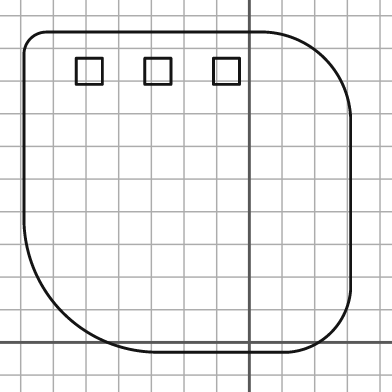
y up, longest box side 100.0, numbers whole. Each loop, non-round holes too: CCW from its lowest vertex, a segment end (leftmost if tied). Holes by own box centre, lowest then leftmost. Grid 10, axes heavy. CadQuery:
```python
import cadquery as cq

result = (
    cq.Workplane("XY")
    .moveTo(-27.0, -3.0)
    .lineTo(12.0, -3.0)
    .threePointArc((25.0, 3.0), (31.0, 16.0))
    .lineTo(31.0, 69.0)
    .threePointArc((23.0, 87.0), (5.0, 95.0))
    .lineTo(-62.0, 95.0)
    .threePointArc((-67.0, 93.0), (-69.0, 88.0))
    .lineTo(-69.0, 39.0)
    .threePointArc((-57.0, 9.0), (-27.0, -3.0))
    .close()
    .moveTo(-53.0, 79.0)
    .lineTo(-45.0, 79.0)
    .lineTo(-45.0, 87.0)
    .lineTo(-53.0, 87.0)
    .close()
    .moveTo(-32.0, 79.0)
    .lineTo(-24.0, 79.0)
    .lineTo(-24.0, 87.0)
    .lineTo(-32.0, 87.0)
    .close()
    .moveTo(-11.0, 79.0)
    .lineTo(-3.0, 79.0)
    .lineTo(-3.0, 87.0)
    .lineTo(-11.0, 87.0)
    .close()
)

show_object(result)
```